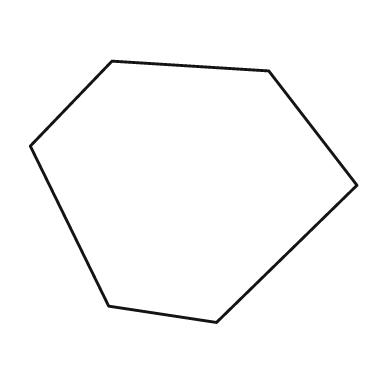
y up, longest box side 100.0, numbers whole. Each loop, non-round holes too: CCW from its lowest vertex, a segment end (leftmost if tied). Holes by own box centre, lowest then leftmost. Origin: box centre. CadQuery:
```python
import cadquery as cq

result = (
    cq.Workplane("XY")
    .moveTo(7.0, -40.0)
    .lineTo(50.0, 2.0)
    .lineTo(23.0, 37.0)
    .lineTo(-25.0, 40.0)
    .lineTo(-50.0, 14.0)
    .lineTo(-26.0, -35.0)
    .close()
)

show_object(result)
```